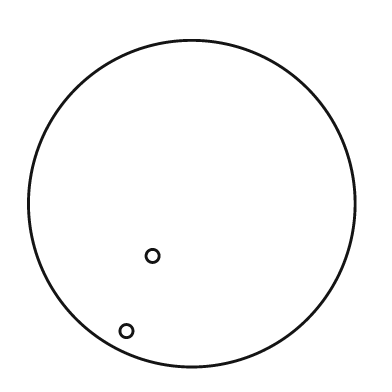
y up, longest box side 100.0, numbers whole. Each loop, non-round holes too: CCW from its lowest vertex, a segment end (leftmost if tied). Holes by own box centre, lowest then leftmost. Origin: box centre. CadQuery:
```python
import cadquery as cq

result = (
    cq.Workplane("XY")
    .moveTo(0.0, 0.0)
    .circle(50.0)
    .moveTo(-20.0, -39.0)
    .circle(2.0)
    .moveTo(-12.0, -16.0)
    .circle(2.0)
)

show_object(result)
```